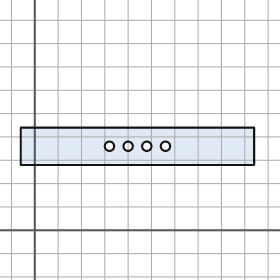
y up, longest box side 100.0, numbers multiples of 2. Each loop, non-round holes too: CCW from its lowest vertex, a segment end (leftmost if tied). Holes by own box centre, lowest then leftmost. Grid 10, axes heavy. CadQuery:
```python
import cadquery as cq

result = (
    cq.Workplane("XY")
    .moveTo(-6.0, 28.0)
    .lineTo(94.0, 28.0)
    .lineTo(94.0, 44.0)
    .lineTo(-6.0, 44.0)
    .close()
    .moveTo(32.0, 36.0)
    .circle(2.0)
    .moveTo(40.0, 36.0)
    .circle(2.0)
    .moveTo(48.0, 36.0)
    .circle(2.0)
    .moveTo(56.0, 36.0)
    .circle(2.0)
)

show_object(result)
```